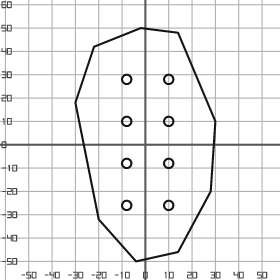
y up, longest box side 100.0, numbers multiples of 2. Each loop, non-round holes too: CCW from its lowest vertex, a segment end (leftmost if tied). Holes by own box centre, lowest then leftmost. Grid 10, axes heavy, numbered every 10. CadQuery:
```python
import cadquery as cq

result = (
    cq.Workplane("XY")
    .moveTo(-4.0, -50.0)
    .lineTo(14.0, -46.0)
    .lineTo(28.0, -20.0)
    .lineTo(30.0, 10.0)
    .lineTo(14.0, 48.0)
    .lineTo(-2.0, 50.0)
    .lineTo(-22.0, 42.0)
    .lineTo(-30.0, 18.0)
    .lineTo(-20.0, -32.0)
    .close()
    .moveTo(-8.0, -26.0)
    .circle(2.0)
    .moveTo(10.0, -26.0)
    .circle(2.0)
    .moveTo(-8.0, -8.0)
    .circle(2.0)
    .moveTo(10.0, -8.0)
    .circle(2.0)
    .moveTo(-8.0, 10.0)
    .circle(2.0)
    .moveTo(10.0, 10.0)
    .circle(2.0)
    .moveTo(-8.0, 28.0)
    .circle(2.0)
    .moveTo(10.0, 28.0)
    .circle(2.0)
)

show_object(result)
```